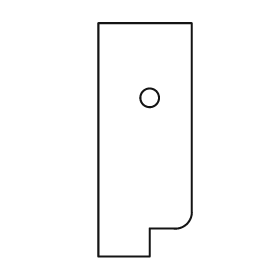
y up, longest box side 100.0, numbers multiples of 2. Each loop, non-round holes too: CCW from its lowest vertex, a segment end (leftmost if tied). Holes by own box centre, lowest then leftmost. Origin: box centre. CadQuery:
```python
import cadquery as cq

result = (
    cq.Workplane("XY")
    .moveTo(-20.0, -50.0)
    .lineTo(2.0, -50.0)
    .lineTo(2.0, -38.0)
    .lineTo(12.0, -38.0)
    .threePointArc((18.0, -36.0), (20.0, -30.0))
    .lineTo(20.0, 50.0)
    .lineTo(-20.0, 50.0)
    .close()
    .moveTo(2.0, 18.0)
    .circle(4.0)
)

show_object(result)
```